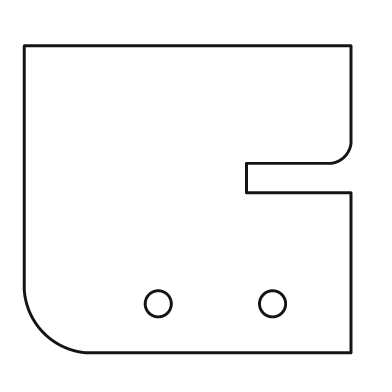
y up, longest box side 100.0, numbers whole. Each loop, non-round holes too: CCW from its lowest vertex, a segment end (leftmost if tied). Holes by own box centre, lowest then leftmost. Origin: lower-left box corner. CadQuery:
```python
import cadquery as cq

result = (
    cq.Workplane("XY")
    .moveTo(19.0, 0.0)
    .lineTo(100.0, 0.0)
    .lineTo(100.0, 49.0)
    .lineTo(68.0, 49.0)
    .lineTo(68.0, 58.0)
    .lineTo(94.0, 58.0)
    .threePointArc((98.0, 60.0), (100.0, 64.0))
    .lineTo(100.0, 94.0)
    .lineTo(0.0, 94.0)
    .lineTo(0.0, 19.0)
    .threePointArc((6.0, 6.0), (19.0, 0.0))
    .close()
    .moveTo(41.0, 15.0)
    .circle(4.0)
    .moveTo(76.0, 15.0)
    .circle(4.0)
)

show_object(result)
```